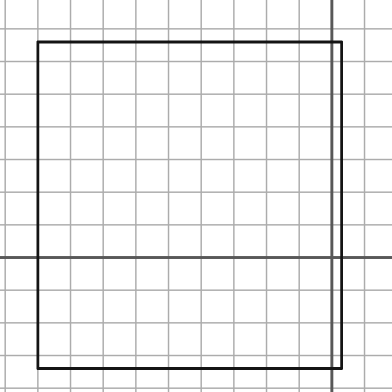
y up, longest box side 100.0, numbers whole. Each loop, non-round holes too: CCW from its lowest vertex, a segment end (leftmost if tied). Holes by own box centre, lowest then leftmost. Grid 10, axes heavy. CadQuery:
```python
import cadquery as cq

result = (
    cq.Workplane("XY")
    .moveTo(-90.0, -34.0)
    .lineTo(3.0, -34.0)
    .lineTo(3.0, 66.0)
    .lineTo(-90.0, 66.0)
    .close()
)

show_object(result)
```